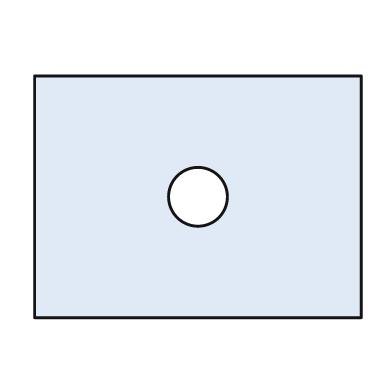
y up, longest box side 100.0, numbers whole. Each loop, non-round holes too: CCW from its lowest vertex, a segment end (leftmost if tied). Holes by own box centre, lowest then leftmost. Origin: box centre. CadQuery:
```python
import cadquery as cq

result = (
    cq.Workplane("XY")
    .moveTo(-50.0, -37.0)
    .lineTo(50.0, -37.0)
    .lineTo(50.0, 37.0)
    .lineTo(-50.0, 37.0)
    .close()
    .moveTo(0.0, 0.0)
    .circle(9.0)
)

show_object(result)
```